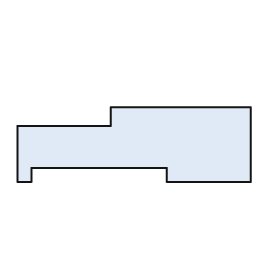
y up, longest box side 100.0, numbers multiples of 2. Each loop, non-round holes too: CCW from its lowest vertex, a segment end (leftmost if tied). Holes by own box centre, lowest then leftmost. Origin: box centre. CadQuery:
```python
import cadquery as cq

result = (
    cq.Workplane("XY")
    .moveTo(-50.0, -16.0)
    .lineTo(-44.0, -16.0)
    .lineTo(-44.0, -10.0)
    .lineTo(14.0, -10.0)
    .lineTo(14.0, -16.0)
    .lineTo(50.0, -16.0)
    .lineTo(50.0, 16.0)
    .lineTo(-10.0, 16.0)
    .lineTo(-10.0, 8.0)
    .lineTo(-50.0, 8.0)
    .close()
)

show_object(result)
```